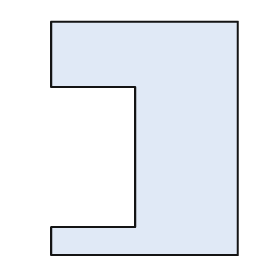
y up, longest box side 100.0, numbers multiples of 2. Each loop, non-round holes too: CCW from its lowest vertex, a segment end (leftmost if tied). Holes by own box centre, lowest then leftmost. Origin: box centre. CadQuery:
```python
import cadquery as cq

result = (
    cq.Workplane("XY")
    .moveTo(-40.0, -50.0)
    .lineTo(40.0, -50.0)
    .lineTo(40.0, 50.0)
    .lineTo(-40.0, 50.0)
    .lineTo(-40.0, 22.0)
    .lineTo(-4.0, 22.0)
    .lineTo(-4.0, -38.0)
    .lineTo(-40.0, -38.0)
    .close()
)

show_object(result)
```